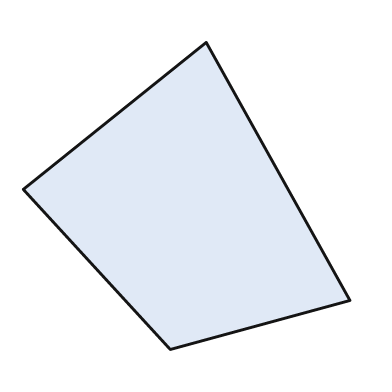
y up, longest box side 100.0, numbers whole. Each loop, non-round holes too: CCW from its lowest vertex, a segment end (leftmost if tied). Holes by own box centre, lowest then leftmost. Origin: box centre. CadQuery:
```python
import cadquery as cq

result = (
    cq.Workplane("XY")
    .moveTo(-5.0, -47.0)
    .lineTo(50.0, -32.0)
    .lineTo(6.0, 47.0)
    .lineTo(-50.0, 2.0)
    .close()
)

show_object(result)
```